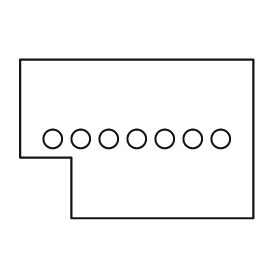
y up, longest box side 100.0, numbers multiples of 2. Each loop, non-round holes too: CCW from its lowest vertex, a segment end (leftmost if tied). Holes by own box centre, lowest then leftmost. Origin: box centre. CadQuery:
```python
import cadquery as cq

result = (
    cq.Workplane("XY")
    .moveTo(-28.0, -34.0)
    .lineTo(50.0, -34.0)
    .lineTo(50.0, 34.0)
    .lineTo(-50.0, 34.0)
    .lineTo(-50.0, -8.0)
    .lineTo(-28.0, -8.0)
    .close()
    .moveTo(-36.0, 0.0)
    .circle(4.0)
    .moveTo(-24.0, 0.0)
    .circle(4.0)
    .moveTo(-12.0, 0.0)
    .circle(4.0)
    .moveTo(0.0, 0.0)
    .circle(4.0)
    .moveTo(12.0, 0.0)
    .circle(4.0)
    .moveTo(24.0, 0.0)
    .circle(4.0)
    .moveTo(36.0, 0.0)
    .circle(4.0)
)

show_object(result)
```